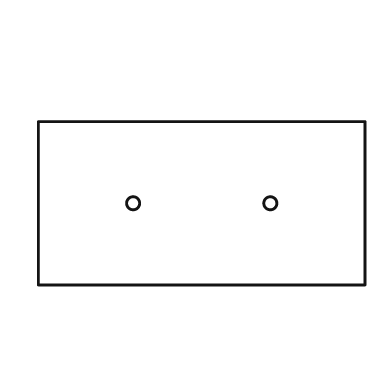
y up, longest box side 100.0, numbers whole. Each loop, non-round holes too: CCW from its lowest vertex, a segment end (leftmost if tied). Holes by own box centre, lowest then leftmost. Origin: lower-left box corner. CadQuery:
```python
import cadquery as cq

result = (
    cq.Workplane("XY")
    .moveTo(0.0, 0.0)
    .lineTo(100.0, 0.0)
    .lineTo(100.0, 50.0)
    .lineTo(0.0, 50.0)
    .close()
    .moveTo(29.0, 25.0)
    .circle(2.0)
    .moveTo(71.0, 25.0)
    .circle(2.0)
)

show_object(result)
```